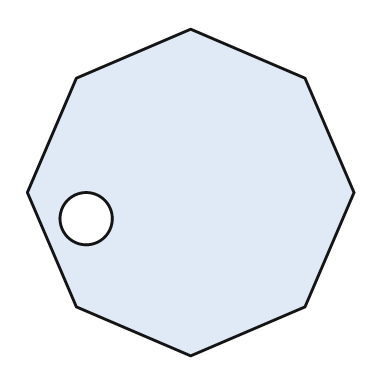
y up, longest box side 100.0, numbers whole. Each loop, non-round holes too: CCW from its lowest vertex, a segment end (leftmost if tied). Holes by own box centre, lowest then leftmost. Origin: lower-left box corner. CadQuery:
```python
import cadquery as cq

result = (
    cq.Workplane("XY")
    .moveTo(50.0, 0.0)
    .lineTo(85.0, 15.0)
    .lineTo(100.0, 50.0)
    .lineTo(85.0, 85.0)
    .lineTo(50.0, 100.0)
    .lineTo(15.0, 85.0)
    .lineTo(0.0, 50.0)
    .lineTo(15.0, 15.0)
    .close()
    .moveTo(18.0, 42.0)
    .circle(8.0)
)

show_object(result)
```